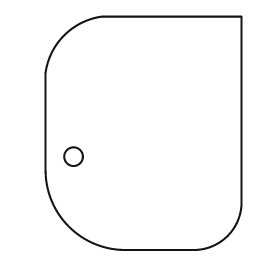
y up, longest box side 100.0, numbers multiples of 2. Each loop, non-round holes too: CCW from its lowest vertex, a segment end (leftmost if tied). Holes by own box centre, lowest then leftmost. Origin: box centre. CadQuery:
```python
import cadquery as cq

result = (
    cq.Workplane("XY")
    .moveTo(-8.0, -50.0)
    .lineTo(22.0, -50.0)
    .threePointArc((36.0, -44.0), (42.0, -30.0))
    .lineTo(42.0, 50.0)
    .lineTo(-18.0, 50.0)
    .threePointArc((-34.0, 42.0), (-42.0, 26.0))
    .lineTo(-42.0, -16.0)
    .threePointArc((-32.0, -40.0), (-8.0, -50.0))
    .close()
    .moveTo(-30.0, -10.0)
    .circle(4.0)
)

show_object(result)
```